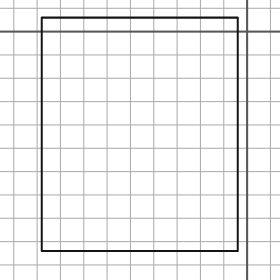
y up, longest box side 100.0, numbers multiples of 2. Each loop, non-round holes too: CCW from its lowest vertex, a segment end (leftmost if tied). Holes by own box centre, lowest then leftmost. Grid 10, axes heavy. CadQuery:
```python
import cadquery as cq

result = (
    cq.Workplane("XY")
    .moveTo(-88.0, -94.0)
    .lineTo(-4.0, -94.0)
    .lineTo(-4.0, 6.0)
    .lineTo(-88.0, 6.0)
    .close()
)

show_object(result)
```